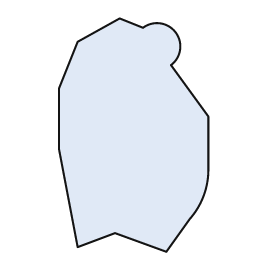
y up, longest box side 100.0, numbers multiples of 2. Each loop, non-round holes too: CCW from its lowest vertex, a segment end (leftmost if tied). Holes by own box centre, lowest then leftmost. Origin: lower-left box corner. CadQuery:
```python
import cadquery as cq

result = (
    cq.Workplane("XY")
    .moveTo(46.0, 0.0)
    .lineTo(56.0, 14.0)
    .threePointArc((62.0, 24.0), (64.0, 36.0))
    .lineTo(64.0, 58.0)
    .lineTo(48.0, 80.0)
    .threePointArc((50.0, 94.0), (36.0, 96.0))
    .lineTo(26.0, 100.0)
    .lineTo(8.0, 90.0)
    .lineTo(0.0, 70.0)
    .lineTo(0.0, 44.0)
    .lineTo(8.0, 2.0)
    .lineTo(24.0, 8.0)
    .close()
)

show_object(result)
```